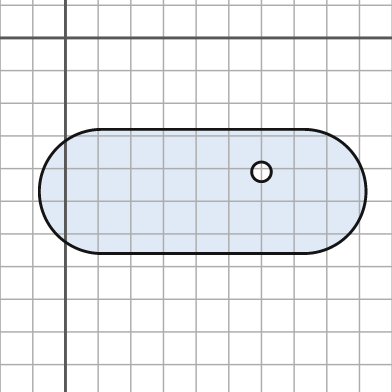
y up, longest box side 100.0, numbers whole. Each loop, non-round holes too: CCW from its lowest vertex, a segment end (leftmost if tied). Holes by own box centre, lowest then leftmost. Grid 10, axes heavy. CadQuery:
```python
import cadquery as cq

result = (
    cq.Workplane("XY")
    .moveTo(11.0, -66.0)
    .lineTo(73.0, -66.0)
    .threePointArc((92.0, -47.0), (73.0, -28.0))
    .lineTo(11.0, -28.0)
    .threePointArc((-8.0, -47.0), (11.0, -66.0))
    .close()
    .moveTo(60.0, -41.0)
    .circle(3.0)
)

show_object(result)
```